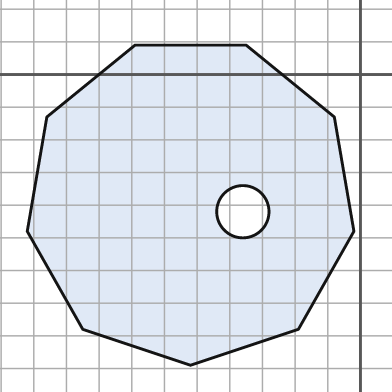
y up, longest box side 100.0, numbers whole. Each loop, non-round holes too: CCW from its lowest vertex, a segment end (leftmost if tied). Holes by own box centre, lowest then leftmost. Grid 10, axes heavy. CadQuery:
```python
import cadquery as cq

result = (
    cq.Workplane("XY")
    .moveTo(-52.0, -89.0)
    .lineTo(-19.0, -78.0)
    .lineTo(-2.0, -48.0)
    .lineTo(-8.0, -13.0)
    .lineTo(-35.0, 9.0)
    .lineTo(-69.0, 9.0)
    .lineTo(-96.0, -13.0)
    .lineTo(-102.0, -48.0)
    .lineTo(-85.0, -78.0)
    .close()
    .moveTo(-36.0, -42.0)
    .circle(8.0)
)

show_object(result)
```